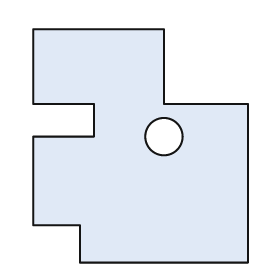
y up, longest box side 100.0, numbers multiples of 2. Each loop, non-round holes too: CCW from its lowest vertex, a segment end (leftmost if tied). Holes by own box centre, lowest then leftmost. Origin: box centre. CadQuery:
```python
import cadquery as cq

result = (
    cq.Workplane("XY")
    .moveTo(-26.0, -50.0)
    .lineTo(46.0, -50.0)
    .lineTo(46.0, 18.0)
    .lineTo(10.0, 18.0)
    .lineTo(10.0, 50.0)
    .lineTo(-46.0, 50.0)
    .lineTo(-46.0, 18.0)
    .lineTo(-20.0, 18.0)
    .lineTo(-20.0, 4.0)
    .lineTo(-46.0, 4.0)
    .lineTo(-46.0, -34.0)
    .lineTo(-26.0, -34.0)
    .close()
    .moveTo(10.0, 4.0)
    .circle(8.0)
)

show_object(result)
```